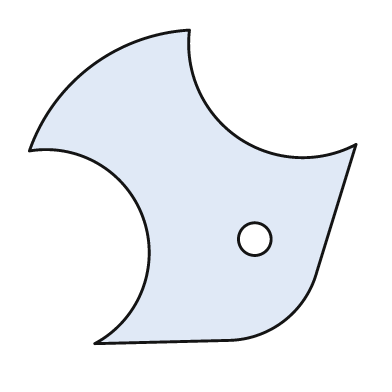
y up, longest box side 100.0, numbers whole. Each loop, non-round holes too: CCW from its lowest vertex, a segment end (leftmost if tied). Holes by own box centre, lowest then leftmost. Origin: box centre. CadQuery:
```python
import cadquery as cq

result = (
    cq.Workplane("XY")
    .moveTo(-30.0, -48.0)
    .lineTo(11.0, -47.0)
    .threePointArc((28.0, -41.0), (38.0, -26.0))
    .lineTo(50.0, 13.0)
    .threePointArc((14.0, 15.0), (-1.0, 48.0))
    .threePointArc((-31.0, 37.0), (-50.0, 11.0))
    .threePointArc((-15.0, -10.0), (-30.0, -48.0))
    .close()
    .moveTo(19.0, -16.0)
    .circle(5.0)
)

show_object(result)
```